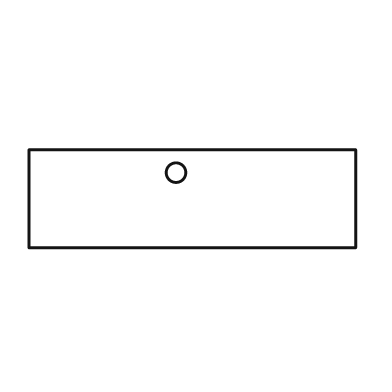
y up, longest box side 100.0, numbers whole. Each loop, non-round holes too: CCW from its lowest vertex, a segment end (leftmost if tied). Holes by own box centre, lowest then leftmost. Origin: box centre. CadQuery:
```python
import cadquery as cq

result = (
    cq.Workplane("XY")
    .moveTo(-50.0, -15.0)
    .lineTo(50.0, -15.0)
    .lineTo(50.0, 15.0)
    .lineTo(-50.0, 15.0)
    .close()
    .moveTo(-5.0, 8.0)
    .circle(3.0)
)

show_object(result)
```